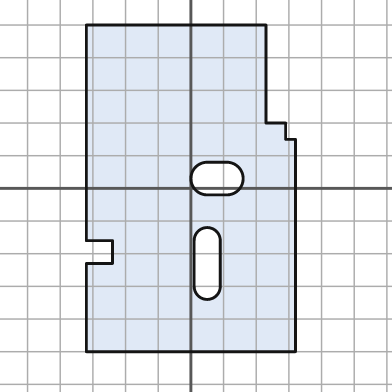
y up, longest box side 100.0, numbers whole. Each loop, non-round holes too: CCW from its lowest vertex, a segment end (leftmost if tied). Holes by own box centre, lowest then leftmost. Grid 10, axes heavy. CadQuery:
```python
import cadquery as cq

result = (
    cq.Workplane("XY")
    .moveTo(-32.0, -50.0)
    .lineTo(32.0, -50.0)
    .lineTo(32.0, 15.0)
    .lineTo(29.0, 15.0)
    .lineTo(29.0, 20.0)
    .lineTo(23.0, 20.0)
    .lineTo(23.0, 50.0)
    .lineTo(-32.0, 50.0)
    .lineTo(-32.0, -16.0)
    .lineTo(-24.0, -16.0)
    .lineTo(-24.0, -23.0)
    .lineTo(-32.0, -23.0)
    .close()
    .moveTo(1.0, -30.0)
    .threePointArc((5.0, -34.0), (9.0, -30.0))
    .lineTo(9.0, -16.0)
    .threePointArc((5.0, -12.0), (1.0, -16.0))
    .close()
    .moveTo(5.0, -2.0)
    .lineTo(11.0, -2.0)
    .threePointArc((16.0, 3.0), (11.0, 8.0))
    .lineTo(5.0, 8.0)
    .threePointArc((0.0, 3.0), (5.0, -2.0))
    .close()
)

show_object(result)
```